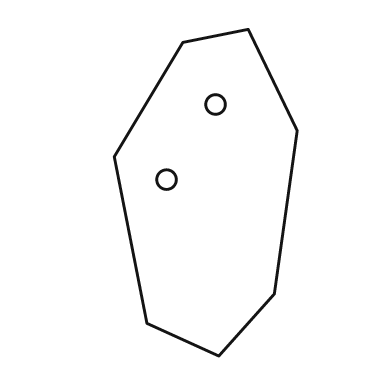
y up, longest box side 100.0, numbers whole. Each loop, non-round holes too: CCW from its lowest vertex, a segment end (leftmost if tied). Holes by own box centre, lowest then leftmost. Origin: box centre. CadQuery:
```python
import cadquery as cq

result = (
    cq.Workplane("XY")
    .moveTo(4.0, -50.0)
    .lineTo(21.0, -31.0)
    .lineTo(28.0, 19.0)
    .lineTo(13.0, 50.0)
    .lineTo(-7.0, 46.0)
    .lineTo(-28.0, 11.0)
    .lineTo(-18.0, -40.0)
    .close()
    .moveTo(-12.0, 4.0)
    .circle(3.0)
    .moveTo(3.0, 27.0)
    .circle(3.0)
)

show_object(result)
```